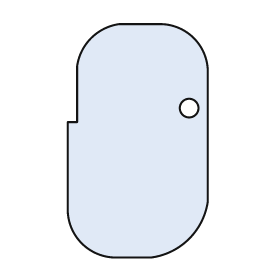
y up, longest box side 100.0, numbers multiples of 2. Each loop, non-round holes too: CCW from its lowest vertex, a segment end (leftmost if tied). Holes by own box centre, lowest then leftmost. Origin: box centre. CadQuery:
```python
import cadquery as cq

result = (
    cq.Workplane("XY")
    .moveTo(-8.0, -50.0)
    .lineTo(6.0, -50.0)
    .threePointArc((22.0, -42.0), (30.0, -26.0))
    .lineTo(30.0, 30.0)
    .threePointArc((24.0, 44.0), (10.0, 50.0))
    .lineTo(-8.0, 50.0)
    .threePointArc((-20.0, 44.0), (-26.0, 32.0))
    .lineTo(-26.0, 8.0)
    .lineTo(-30.0, 8.0)
    .lineTo(-30.0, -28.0)
    .threePointArc((-24.0, -44.0), (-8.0, -50.0))
    .close()
    .moveTo(22.0, 14.0)
    .circle(4.0)
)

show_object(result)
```